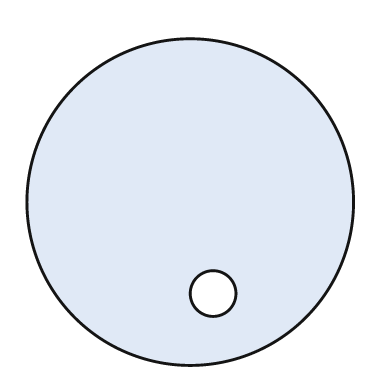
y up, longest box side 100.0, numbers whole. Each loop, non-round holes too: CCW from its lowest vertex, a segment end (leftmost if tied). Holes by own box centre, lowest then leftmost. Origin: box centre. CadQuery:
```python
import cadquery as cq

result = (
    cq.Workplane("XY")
    .moveTo(0.0, 0.0)
    .circle(50.0)
    .moveTo(7.0, -28.0)
    .circle(7.0)
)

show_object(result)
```